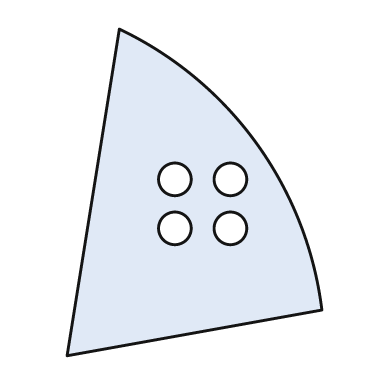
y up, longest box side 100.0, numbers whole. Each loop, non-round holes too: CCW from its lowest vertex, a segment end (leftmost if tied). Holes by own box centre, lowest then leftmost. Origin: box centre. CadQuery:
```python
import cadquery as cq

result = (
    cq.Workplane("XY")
    .moveTo(-39.0, -50.0)
    .lineTo(39.0, -36.0)
    .threePointArc((19.0, 15.0), (-23.0, 50.0))
    .close()
    .moveTo(-6.0, -11.0)
    .circle(5.0)
    .moveTo(11.0, -11.0)
    .circle(5.0)
    .moveTo(-6.0, 4.0)
    .circle(5.0)
    .moveTo(11.0, 4.0)
    .circle(5.0)
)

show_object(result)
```